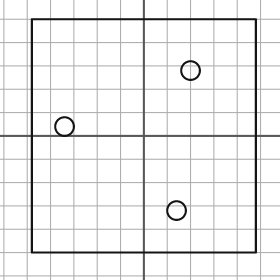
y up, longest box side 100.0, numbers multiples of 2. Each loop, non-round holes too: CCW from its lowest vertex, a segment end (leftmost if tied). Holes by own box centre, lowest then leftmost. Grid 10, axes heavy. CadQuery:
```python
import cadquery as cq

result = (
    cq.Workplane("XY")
    .moveTo(-48.0, -50.0)
    .lineTo(48.0, -50.0)
    .lineTo(48.0, 50.0)
    .lineTo(-48.0, 50.0)
    .close()
    .moveTo(14.0, -32.0)
    .circle(4.0)
    .moveTo(-34.0, 4.0)
    .circle(4.0)
    .moveTo(20.0, 28.0)
    .circle(4.0)
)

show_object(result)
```